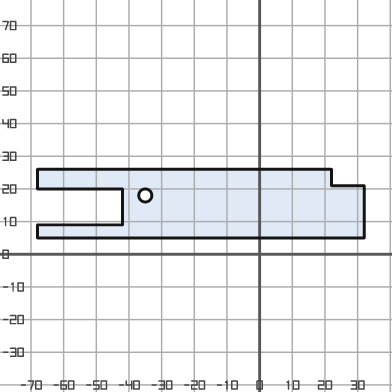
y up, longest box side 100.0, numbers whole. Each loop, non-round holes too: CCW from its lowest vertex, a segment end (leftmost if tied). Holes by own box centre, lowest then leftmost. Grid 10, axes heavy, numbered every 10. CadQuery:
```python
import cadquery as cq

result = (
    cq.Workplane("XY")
    .moveTo(-68.0, 5.0)
    .lineTo(32.0, 5.0)
    .lineTo(32.0, 21.0)
    .lineTo(22.0, 21.0)
    .lineTo(22.0, 26.0)
    .lineTo(-68.0, 26.0)
    .lineTo(-68.0, 20.0)
    .lineTo(-42.0, 20.0)
    .lineTo(-42.0, 9.0)
    .lineTo(-68.0, 9.0)
    .close()
    .moveTo(-35.0, 18.0)
    .circle(2.0)
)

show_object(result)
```